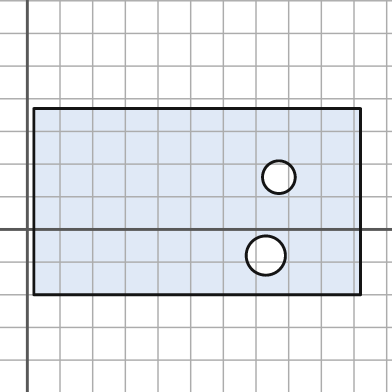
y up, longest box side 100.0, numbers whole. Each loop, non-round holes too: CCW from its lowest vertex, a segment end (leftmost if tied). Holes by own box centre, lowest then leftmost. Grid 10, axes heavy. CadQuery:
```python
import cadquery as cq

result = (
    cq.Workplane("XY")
    .moveTo(2.0, -20.0)
    .lineTo(102.0, -20.0)
    .lineTo(102.0, 37.0)
    .lineTo(2.0, 37.0)
    .close()
    .moveTo(73.0, -8.0)
    .circle(6.0)
    .moveTo(77.0, 16.0)
    .circle(5.0)
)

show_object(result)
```